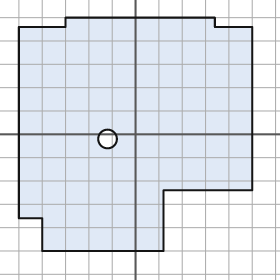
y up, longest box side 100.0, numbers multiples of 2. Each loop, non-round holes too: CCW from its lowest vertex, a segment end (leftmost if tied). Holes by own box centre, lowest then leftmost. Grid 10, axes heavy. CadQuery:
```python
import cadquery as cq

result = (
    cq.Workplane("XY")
    .moveTo(-40.0, -50.0)
    .lineTo(12.0, -50.0)
    .lineTo(12.0, -24.0)
    .lineTo(50.0, -24.0)
    .lineTo(50.0, 46.0)
    .lineTo(34.0, 46.0)
    .lineTo(34.0, 50.0)
    .lineTo(-30.0, 50.0)
    .lineTo(-30.0, 46.0)
    .lineTo(-50.0, 46.0)
    .lineTo(-50.0, -36.0)
    .lineTo(-40.0, -36.0)
    .close()
    .moveTo(-12.0, -2.0)
    .circle(4.0)
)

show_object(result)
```